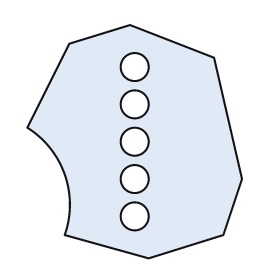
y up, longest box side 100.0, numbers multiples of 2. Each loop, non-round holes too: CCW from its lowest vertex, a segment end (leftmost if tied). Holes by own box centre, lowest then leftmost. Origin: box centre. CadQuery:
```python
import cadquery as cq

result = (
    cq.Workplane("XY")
    .moveTo(6.0, -50.0)
    .lineTo(38.0, -40.0)
    .lineTo(46.0, -16.0)
    .lineTo(34.0, 36.0)
    .lineTo(-2.0, 50.0)
    .lineTo(-28.0, 42.0)
    .lineTo(-46.0, 6.0)
    .threePointArc((-30.0, -14.0), (-30.0, -40.0))
    .close()
    .moveTo(0.0, -32.0)
    .circle(6.0)
    .moveTo(0.0, -16.0)
    .circle(6.0)
    .moveTo(0.0, 0.0)
    .circle(6.0)
    .moveTo(0.0, 16.0)
    .circle(6.0)
    .moveTo(0.0, 32.0)
    .circle(6.0)
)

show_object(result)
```